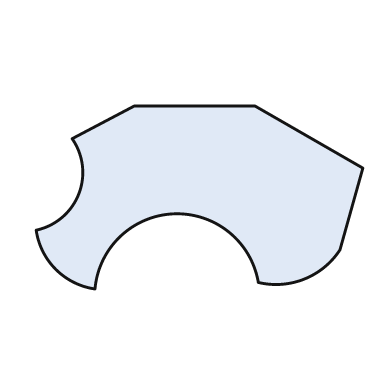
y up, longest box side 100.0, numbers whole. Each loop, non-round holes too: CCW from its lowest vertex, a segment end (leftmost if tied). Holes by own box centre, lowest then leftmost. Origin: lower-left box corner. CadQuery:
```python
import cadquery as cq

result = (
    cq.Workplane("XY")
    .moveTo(18.0, 0.0)
    .threePointArc((42.0, 23.0), (68.0, 2.0))
    .threePointArc((82.0, 3.0), (93.0, 12.0))
    .lineTo(100.0, 37.0)
    .lineTo(67.0, 56.0)
    .lineTo(30.0, 56.0)
    .lineTo(11.0, 46.0)
    .threePointArc((13.0, 29.0), (0.0, 18.0))
    .threePointArc((6.0, 6.0), (18.0, 0.0))
    .close()
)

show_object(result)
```